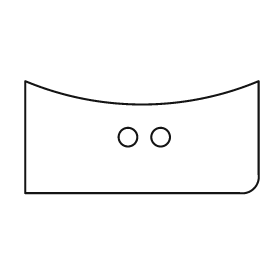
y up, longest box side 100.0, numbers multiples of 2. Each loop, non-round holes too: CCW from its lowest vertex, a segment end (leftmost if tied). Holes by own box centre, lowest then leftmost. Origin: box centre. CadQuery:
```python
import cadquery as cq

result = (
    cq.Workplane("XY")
    .moveTo(-50.0, -24.0)
    .lineTo(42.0, -24.0)
    .threePointArc((48.0, -22.0), (50.0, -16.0))
    .lineTo(50.0, 24.0)
    .threePointArc((0.0, 14.0), (-50.0, 24.0))
    .close()
    .moveTo(-6.0, 0.0)
    .circle(4.0)
    .moveTo(8.0, 0.0)
    .circle(4.0)
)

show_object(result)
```